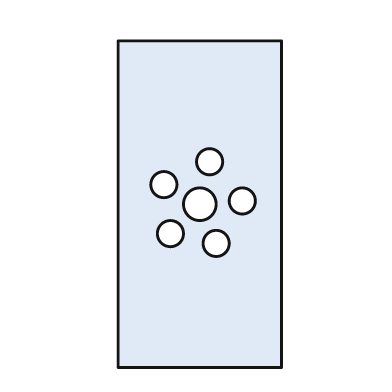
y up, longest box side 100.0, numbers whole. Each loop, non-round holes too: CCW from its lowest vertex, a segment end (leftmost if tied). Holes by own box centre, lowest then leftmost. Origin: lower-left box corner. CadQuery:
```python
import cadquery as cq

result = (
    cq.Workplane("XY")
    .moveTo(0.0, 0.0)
    .lineTo(50.0, 0.0)
    .lineTo(50.0, 100.0)
    .lineTo(0.0, 100.0)
    .close()
    .moveTo(30.0, 38.0)
    .circle(4.0)
    .moveTo(16.0, 41.0)
    .circle(4.0)
    .moveTo(25.0, 50.0)
    .circle(5.0)
    .moveTo(38.0, 51.0)
    .circle(4.0)
    .moveTo(14.0, 56.0)
    .circle(4.0)
    .moveTo(28.0, 63.0)
    .circle(4.0)
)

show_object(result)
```